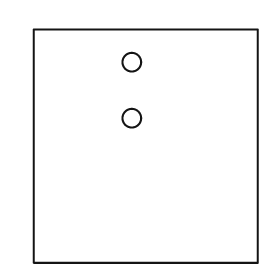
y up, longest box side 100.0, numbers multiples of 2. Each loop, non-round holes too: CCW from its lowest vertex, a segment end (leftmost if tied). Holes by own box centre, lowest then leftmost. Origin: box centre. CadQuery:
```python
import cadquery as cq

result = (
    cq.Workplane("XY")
    .moveTo(-48.0, -50.0)
    .lineTo(48.0, -50.0)
    .lineTo(48.0, 50.0)
    .lineTo(-48.0, 50.0)
    .close()
    .moveTo(-6.0, 12.0)
    .circle(4.0)
    .moveTo(-6.0, 36.0)
    .circle(4.0)
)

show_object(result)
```